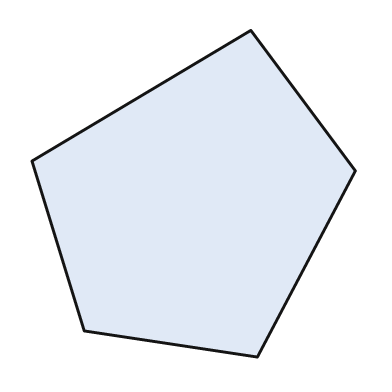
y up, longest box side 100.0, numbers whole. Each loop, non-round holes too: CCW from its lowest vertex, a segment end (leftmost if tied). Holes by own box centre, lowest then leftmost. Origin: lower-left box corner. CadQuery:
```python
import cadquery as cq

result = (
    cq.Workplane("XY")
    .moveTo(69.0, 0.0)
    .lineTo(99.0, 57.0)
    .lineTo(67.0, 100.0)
    .lineTo(0.0, 60.0)
    .lineTo(16.0, 8.0)
    .close()
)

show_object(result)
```